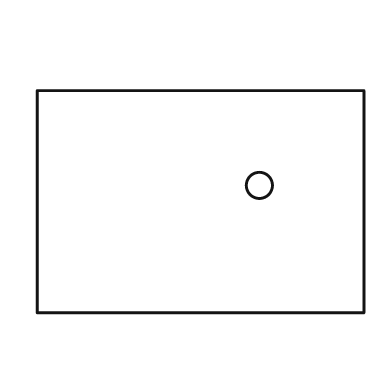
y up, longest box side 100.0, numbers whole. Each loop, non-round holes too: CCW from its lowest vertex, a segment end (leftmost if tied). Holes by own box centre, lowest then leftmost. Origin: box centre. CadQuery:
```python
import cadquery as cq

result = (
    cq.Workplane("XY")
    .moveTo(-50.0, -34.0)
    .lineTo(50.0, -34.0)
    .lineTo(50.0, 34.0)
    .lineTo(-50.0, 34.0)
    .close()
    .moveTo(18.0, 5.0)
    .circle(4.0)
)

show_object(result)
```